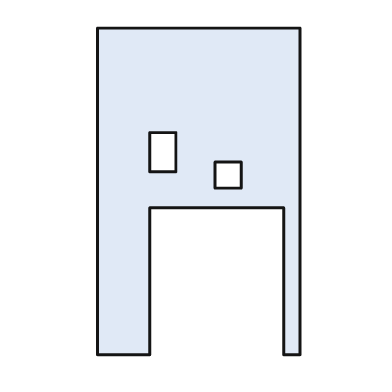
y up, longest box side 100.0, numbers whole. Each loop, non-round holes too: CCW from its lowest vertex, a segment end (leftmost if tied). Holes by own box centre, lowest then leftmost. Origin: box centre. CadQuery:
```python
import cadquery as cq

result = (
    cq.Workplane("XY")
    .moveTo(-31.0, -50.0)
    .lineTo(-15.0, -50.0)
    .lineTo(-15.0, -5.0)
    .lineTo(26.0, -5.0)
    .lineTo(26.0, -50.0)
    .lineTo(31.0, -50.0)
    .lineTo(31.0, 50.0)
    .lineTo(-31.0, 50.0)
    .close()
    .moveTo(5.0, 1.0)
    .lineTo(13.0, 1.0)
    .lineTo(13.0, 9.0)
    .lineTo(5.0, 9.0)
    .close()
    .moveTo(-15.0, 6.0)
    .lineTo(-7.0, 6.0)
    .lineTo(-7.0, 18.0)
    .lineTo(-15.0, 18.0)
    .close()
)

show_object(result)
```